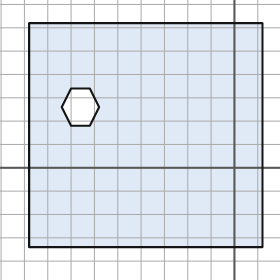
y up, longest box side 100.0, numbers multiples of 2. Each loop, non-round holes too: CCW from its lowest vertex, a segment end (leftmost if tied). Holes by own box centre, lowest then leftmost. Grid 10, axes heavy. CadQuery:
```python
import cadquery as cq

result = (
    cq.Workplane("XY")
    .moveTo(-88.0, -34.0)
    .lineTo(12.0, -34.0)
    .lineTo(12.0, 62.0)
    .lineTo(-88.0, 62.0)
    .close()
    .moveTo(-70.0, 18.0)
    .lineTo(-62.0, 18.0)
    .lineTo(-58.0, 26.0)
    .lineTo(-62.0, 34.0)
    .lineTo(-70.0, 34.0)
    .lineTo(-74.0, 26.0)
    .close()
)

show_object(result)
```